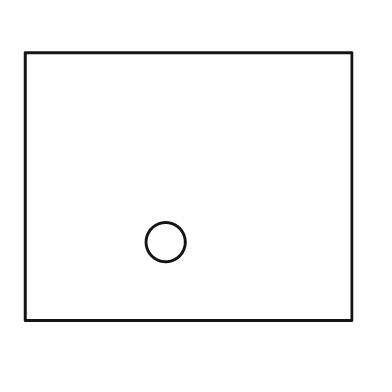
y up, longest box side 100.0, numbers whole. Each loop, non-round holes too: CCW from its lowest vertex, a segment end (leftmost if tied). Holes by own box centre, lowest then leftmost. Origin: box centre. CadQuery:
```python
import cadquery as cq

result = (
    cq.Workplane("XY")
    .moveTo(-50.0, -41.0)
    .lineTo(50.0, -41.0)
    .lineTo(50.0, 41.0)
    .lineTo(-50.0, 41.0)
    .close()
    .moveTo(-7.0, -17.0)
    .circle(6.0)
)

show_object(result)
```